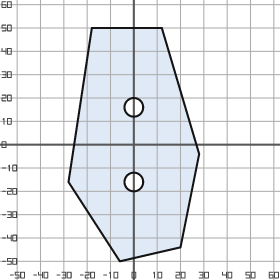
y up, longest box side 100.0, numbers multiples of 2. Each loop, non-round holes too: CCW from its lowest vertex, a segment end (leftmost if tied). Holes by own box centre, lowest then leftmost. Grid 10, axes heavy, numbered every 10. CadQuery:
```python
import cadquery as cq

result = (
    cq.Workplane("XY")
    .moveTo(-6.0, -50.0)
    .lineTo(20.0, -44.0)
    .lineTo(28.0, -4.0)
    .lineTo(12.0, 50.0)
    .lineTo(-18.0, 50.0)
    .lineTo(-28.0, -16.0)
    .close()
    .moveTo(0.0, -16.0)
    .circle(4.0)
    .moveTo(0.0, 16.0)
    .circle(4.0)
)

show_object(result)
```